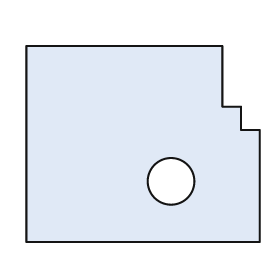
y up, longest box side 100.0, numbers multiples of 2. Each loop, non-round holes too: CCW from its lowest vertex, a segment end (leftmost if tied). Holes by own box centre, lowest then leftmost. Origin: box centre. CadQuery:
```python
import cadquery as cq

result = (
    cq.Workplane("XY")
    .moveTo(-50.0, -42.0)
    .lineTo(50.0, -42.0)
    .lineTo(50.0, 6.0)
    .lineTo(42.0, 6.0)
    .lineTo(42.0, 16.0)
    .lineTo(34.0, 16.0)
    .lineTo(34.0, 42.0)
    .lineTo(-50.0, 42.0)
    .close()
    .moveTo(12.0, -16.0)
    .circle(10.0)
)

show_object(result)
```